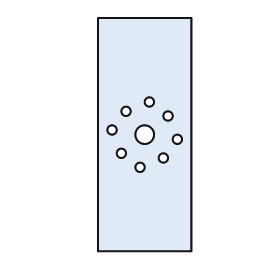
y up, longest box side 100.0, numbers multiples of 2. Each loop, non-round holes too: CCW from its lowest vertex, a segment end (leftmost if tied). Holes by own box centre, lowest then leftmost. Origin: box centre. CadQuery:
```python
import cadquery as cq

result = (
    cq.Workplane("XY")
    .moveTo(-20.0, -50.0)
    .lineTo(20.0, -50.0)
    .lineTo(20.0, 50.0)
    .lineTo(-20.0, 50.0)
    .close()
    .moveTo(-2.0, -14.0)
    .circle(2.0)
    .moveTo(8.0, -10.0)
    .circle(2.0)
    .moveTo(-10.0, -8.0)
    .circle(2.0)
    .moveTo(14.0, -2.0)
    .circle(2.0)
    .moveTo(0.0, 0.0)
    .circle(4.0)
    .moveTo(-14.0, 2.0)
    .circle(2.0)
    .moveTo(10.0, 8.0)
    .circle(2.0)
    .moveTo(-8.0, 10.0)
    .circle(2.0)
    .moveTo(2.0, 14.0)
    .circle(2.0)
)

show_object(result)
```